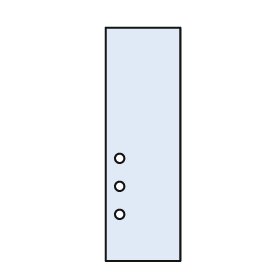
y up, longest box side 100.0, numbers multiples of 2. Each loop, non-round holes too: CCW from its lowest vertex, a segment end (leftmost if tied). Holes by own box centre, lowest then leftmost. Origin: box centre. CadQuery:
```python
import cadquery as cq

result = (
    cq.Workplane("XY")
    .moveTo(-16.0, -50.0)
    .lineTo(16.0, -50.0)
    .lineTo(16.0, 50.0)
    .lineTo(-16.0, 50.0)
    .close()
    .moveTo(-10.0, -30.0)
    .circle(2.0)
    .moveTo(-10.0, -18.0)
    .circle(2.0)
    .moveTo(-10.0, -6.0)
    .circle(2.0)
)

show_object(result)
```